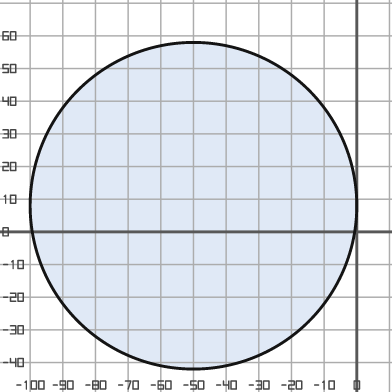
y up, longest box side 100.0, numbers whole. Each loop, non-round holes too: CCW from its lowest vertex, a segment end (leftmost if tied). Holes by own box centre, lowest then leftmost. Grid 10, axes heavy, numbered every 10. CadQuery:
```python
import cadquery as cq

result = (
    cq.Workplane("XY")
    .moveTo(-50.0, 8.0)
    .circle(50.0)
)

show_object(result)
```